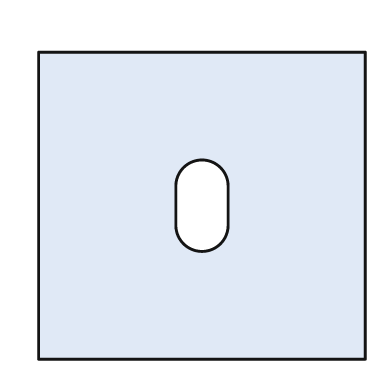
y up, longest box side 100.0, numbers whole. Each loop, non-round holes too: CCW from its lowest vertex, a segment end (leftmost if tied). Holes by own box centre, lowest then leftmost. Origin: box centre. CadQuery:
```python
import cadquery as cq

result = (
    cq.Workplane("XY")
    .moveTo(-50.0, -47.0)
    .lineTo(50.0, -47.0)
    .lineTo(50.0, 47.0)
    .lineTo(-50.0, 47.0)
    .close()
    .moveTo(-8.0, -6.0)
    .threePointArc((0.0, -14.0), (8.0, -6.0))
    .lineTo(8.0, 6.0)
    .threePointArc((0.0, 14.0), (-8.0, 6.0))
    .close()
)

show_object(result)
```